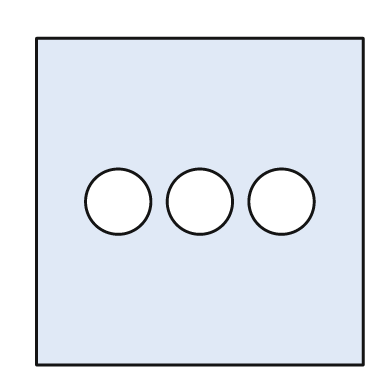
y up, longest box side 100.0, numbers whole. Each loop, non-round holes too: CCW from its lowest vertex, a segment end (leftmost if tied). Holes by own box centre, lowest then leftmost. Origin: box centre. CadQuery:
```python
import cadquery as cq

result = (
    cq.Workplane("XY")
    .moveTo(-50.0, -50.0)
    .lineTo(50.0, -50.0)
    .lineTo(50.0, 50.0)
    .lineTo(-50.0, 50.0)
    .close()
    .moveTo(-25.0, 0.0)
    .circle(10.0)
    .moveTo(0.0, 0.0)
    .circle(10.0)
    .moveTo(25.0, 0.0)
    .circle(10.0)
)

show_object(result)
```